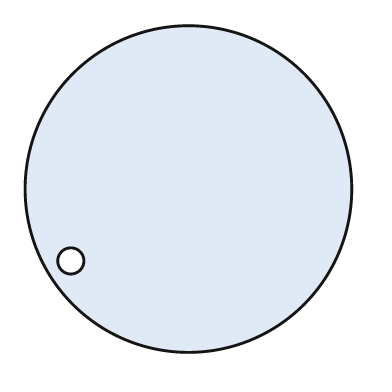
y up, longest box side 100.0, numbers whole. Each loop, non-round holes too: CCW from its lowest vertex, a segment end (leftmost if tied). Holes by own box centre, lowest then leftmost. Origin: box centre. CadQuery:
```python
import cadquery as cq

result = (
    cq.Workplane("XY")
    .moveTo(0.0, 0.0)
    .circle(50.0)
    .moveTo(-36.0, -22.0)
    .circle(4.0)
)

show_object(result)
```